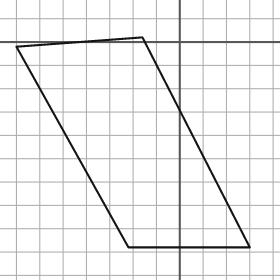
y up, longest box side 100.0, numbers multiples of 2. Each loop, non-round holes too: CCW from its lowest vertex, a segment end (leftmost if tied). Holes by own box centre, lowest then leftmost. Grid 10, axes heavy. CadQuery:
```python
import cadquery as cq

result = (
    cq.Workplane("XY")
    .moveTo(-22.0, -88.0)
    .lineTo(30.0, -88.0)
    .lineTo(-16.0, 2.0)
    .lineTo(-70.0, -2.0)
    .close()
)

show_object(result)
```